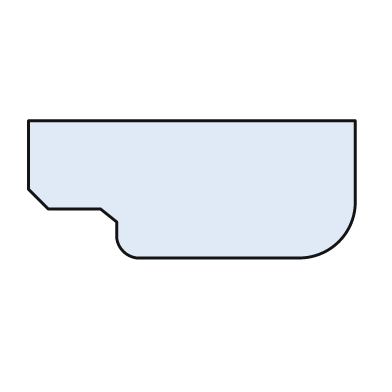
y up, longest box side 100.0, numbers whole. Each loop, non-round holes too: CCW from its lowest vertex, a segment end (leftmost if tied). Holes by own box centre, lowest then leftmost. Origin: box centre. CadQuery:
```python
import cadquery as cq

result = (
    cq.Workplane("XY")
    .moveTo(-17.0, -21.0)
    .lineTo(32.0, -21.0)
    .threePointArc((45.0, -16.0), (50.0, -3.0))
    .lineTo(50.0, 21.0)
    .lineTo(-50.0, 21.0)
    .lineTo(-50.0, 0.0)
    .lineTo(-44.0, -6.0)
    .lineTo(-28.0, -6.0)
    .lineTo(-23.0, -10.0)
    .lineTo(-23.0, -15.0)
    .threePointArc((-21.0, -19.0), (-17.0, -21.0))
    .close()
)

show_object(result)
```